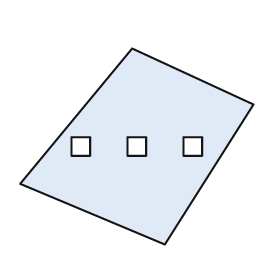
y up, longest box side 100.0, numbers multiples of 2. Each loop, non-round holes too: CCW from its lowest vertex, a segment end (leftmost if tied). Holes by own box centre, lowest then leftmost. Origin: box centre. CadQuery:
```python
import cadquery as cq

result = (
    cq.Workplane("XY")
    .moveTo(12.0, -42.0)
    .lineTo(50.0, 18.0)
    .lineTo(-2.0, 42.0)
    .lineTo(-50.0, -16.0)
    .close()
    .moveTo(-28.0, -4.0)
    .lineTo(-20.0, -4.0)
    .lineTo(-20.0, 4.0)
    .lineTo(-28.0, 4.0)
    .close()
    .moveTo(-4.0, -4.0)
    .lineTo(4.0, -4.0)
    .lineTo(4.0, 4.0)
    .lineTo(-4.0, 4.0)
    .close()
    .moveTo(20.0, -4.0)
    .lineTo(28.0, -4.0)
    .lineTo(28.0, 4.0)
    .lineTo(20.0, 4.0)
    .close()
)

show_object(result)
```